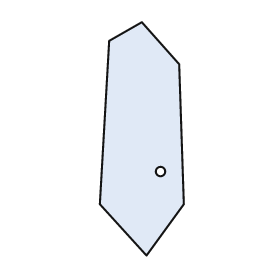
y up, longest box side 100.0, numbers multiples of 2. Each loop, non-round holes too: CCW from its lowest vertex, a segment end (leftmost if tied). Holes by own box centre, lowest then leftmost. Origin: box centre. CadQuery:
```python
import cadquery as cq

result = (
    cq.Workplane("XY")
    .moveTo(2.0, -50.0)
    .lineTo(18.0, -28.0)
    .lineTo(16.0, 32.0)
    .lineTo(0.0, 50.0)
    .lineTo(-14.0, 42.0)
    .lineTo(-18.0, -28.0)
    .close()
    .moveTo(8.0, -14.0)
    .circle(2.0)
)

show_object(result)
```